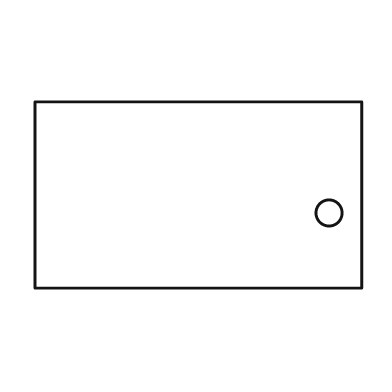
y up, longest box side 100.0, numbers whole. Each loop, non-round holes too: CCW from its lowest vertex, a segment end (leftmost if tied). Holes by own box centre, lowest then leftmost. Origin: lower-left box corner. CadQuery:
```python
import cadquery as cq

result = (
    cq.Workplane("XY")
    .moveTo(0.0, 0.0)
    .lineTo(100.0, 0.0)
    .lineTo(100.0, 57.0)
    .lineTo(0.0, 57.0)
    .close()
    .moveTo(90.0, 23.0)
    .circle(4.0)
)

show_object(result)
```